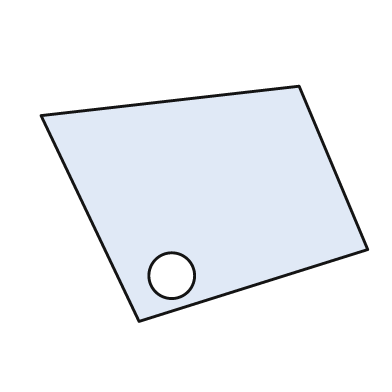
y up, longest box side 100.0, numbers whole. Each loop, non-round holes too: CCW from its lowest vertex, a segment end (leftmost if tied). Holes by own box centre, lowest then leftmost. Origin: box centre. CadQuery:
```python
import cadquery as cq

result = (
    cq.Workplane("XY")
    .moveTo(-20.0, -36.0)
    .lineTo(50.0, -14.0)
    .lineTo(29.0, 36.0)
    .lineTo(-50.0, 27.0)
    .close()
    .moveTo(-10.0, -22.0)
    .circle(7.0)
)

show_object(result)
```